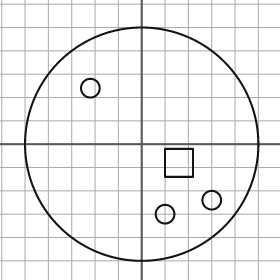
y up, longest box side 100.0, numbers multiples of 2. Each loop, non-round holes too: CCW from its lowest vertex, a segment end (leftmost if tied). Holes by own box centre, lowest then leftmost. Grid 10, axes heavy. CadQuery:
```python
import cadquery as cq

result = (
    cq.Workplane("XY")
    .moveTo(0.0, 0.0)
    .circle(50.0)
    .moveTo(10.0, -30.0)
    .circle(4.0)
    .moveTo(30.0, -24.0)
    .circle(4.0)
    .moveTo(10.0, -14.0)
    .lineTo(22.0, -14.0)
    .lineTo(22.0, -2.0)
    .lineTo(10.0, -2.0)
    .close()
    .moveTo(-22.0, 24.0)
    .circle(4.0)
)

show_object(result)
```